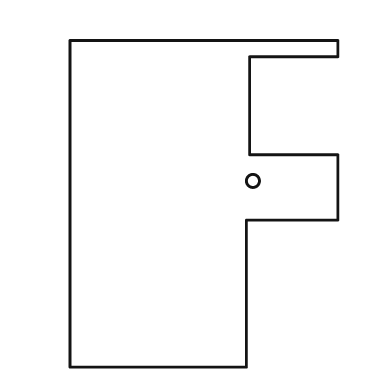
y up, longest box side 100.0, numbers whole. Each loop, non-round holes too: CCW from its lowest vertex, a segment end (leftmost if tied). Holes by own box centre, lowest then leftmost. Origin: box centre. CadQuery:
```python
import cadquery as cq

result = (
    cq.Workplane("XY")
    .moveTo(-41.0, -50.0)
    .lineTo(13.0, -50.0)
    .lineTo(13.0, -5.0)
    .lineTo(41.0, -5.0)
    .lineTo(41.0, 15.0)
    .lineTo(14.0, 15.0)
    .lineTo(14.0, 45.0)
    .lineTo(41.0, 45.0)
    .lineTo(41.0, 50.0)
    .lineTo(-41.0, 50.0)
    .close()
    .moveTo(15.0, 7.0)
    .circle(2.0)
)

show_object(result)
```